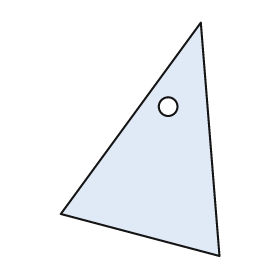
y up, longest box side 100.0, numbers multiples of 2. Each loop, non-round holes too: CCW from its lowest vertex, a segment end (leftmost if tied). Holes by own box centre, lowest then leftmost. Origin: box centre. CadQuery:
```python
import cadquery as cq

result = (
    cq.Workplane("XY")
    .moveTo(34.0, -50.0)
    .lineTo(26.0, 50.0)
    .lineTo(-34.0, -32.0)
    .close()
    .moveTo(12.0, 14.0)
    .circle(4.0)
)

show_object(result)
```